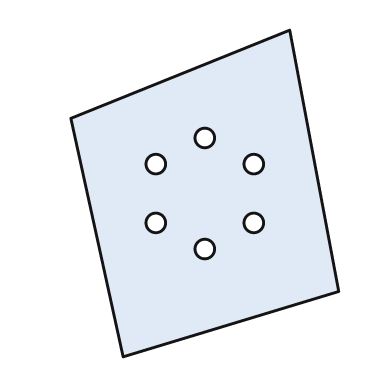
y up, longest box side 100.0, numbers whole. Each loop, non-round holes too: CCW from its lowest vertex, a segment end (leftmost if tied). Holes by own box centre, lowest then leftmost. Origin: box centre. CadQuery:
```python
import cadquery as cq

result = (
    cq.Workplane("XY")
    .moveTo(-25.0, -50.0)
    .lineTo(41.0, -30.0)
    .lineTo(26.0, 50.0)
    .lineTo(-41.0, 23.0)
    .close()
    .moveTo(0.0, -17.0)
    .circle(3.0)
    .moveTo(-15.0, -9.0)
    .circle(3.0)
    .moveTo(15.0, -9.0)
    .circle(3.0)
    .moveTo(-15.0, 9.0)
    .circle(3.0)
    .moveTo(15.0, 9.0)
    .circle(3.0)
    .moveTo(0.0, 17.0)
    .circle(3.0)
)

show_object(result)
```